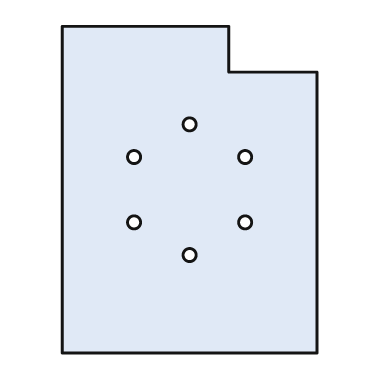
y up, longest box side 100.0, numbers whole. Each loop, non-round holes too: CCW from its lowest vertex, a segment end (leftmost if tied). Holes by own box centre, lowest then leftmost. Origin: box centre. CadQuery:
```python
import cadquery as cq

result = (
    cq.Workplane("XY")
    .moveTo(-39.0, -50.0)
    .lineTo(39.0, -50.0)
    .lineTo(39.0, 36.0)
    .lineTo(12.0, 36.0)
    .lineTo(12.0, 50.0)
    .lineTo(-39.0, 50.0)
    .close()
    .moveTo(0.0, -20.0)
    .circle(2.0)
    .moveTo(-17.0, -10.0)
    .circle(2.0)
    .moveTo(17.0, -10.0)
    .circle(2.0)
    .moveTo(-17.0, 10.0)
    .circle(2.0)
    .moveTo(17.0, 10.0)
    .circle(2.0)
    .moveTo(0.0, 20.0)
    .circle(2.0)
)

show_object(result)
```